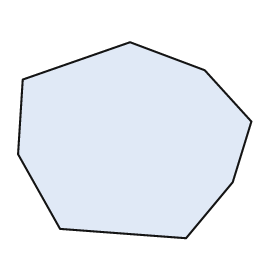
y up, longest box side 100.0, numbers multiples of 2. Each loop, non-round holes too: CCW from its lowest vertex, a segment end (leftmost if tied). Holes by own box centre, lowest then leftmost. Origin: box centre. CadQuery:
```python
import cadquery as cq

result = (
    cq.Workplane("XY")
    .moveTo(22.0, -42.0)
    .lineTo(42.0, -18.0)
    .lineTo(50.0, 8.0)
    .lineTo(30.0, 30.0)
    .lineTo(-2.0, 42.0)
    .lineTo(-48.0, 26.0)
    .lineTo(-50.0, -6.0)
    .lineTo(-32.0, -38.0)
    .close()
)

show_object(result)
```